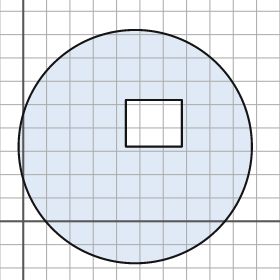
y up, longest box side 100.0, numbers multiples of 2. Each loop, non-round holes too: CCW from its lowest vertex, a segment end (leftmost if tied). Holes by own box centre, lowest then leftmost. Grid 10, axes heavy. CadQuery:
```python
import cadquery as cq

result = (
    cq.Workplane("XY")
    .moveTo(48.0, 32.0)
    .circle(50.0)
    .moveTo(44.0, 32.0)
    .lineTo(68.0, 32.0)
    .lineTo(68.0, 52.0)
    .lineTo(44.0, 52.0)
    .close()
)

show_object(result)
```